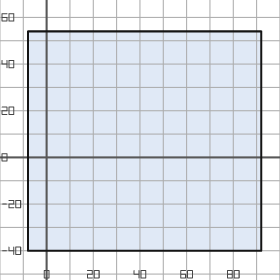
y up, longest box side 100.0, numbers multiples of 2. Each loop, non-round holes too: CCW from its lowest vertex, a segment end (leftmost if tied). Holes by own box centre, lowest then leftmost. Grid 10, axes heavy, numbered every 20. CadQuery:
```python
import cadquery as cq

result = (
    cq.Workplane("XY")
    .moveTo(-8.0, -40.0)
    .lineTo(92.0, -40.0)
    .lineTo(92.0, 54.0)
    .lineTo(-8.0, 54.0)
    .close()
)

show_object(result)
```